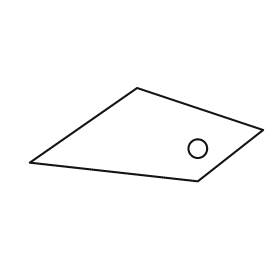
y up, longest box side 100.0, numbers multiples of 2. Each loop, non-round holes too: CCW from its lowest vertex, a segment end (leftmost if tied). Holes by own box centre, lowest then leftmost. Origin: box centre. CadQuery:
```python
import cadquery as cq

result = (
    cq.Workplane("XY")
    .moveTo(22.0, -20.0)
    .lineTo(50.0, 2.0)
    .lineTo(-4.0, 20.0)
    .lineTo(-50.0, -12.0)
    .close()
    .moveTo(22.0, -6.0)
    .circle(4.0)
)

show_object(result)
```